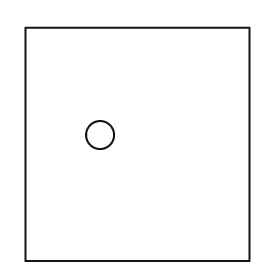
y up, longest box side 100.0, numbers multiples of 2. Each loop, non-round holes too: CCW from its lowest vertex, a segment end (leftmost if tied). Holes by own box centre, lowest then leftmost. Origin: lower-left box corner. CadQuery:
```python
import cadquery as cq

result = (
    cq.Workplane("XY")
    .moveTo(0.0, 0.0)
    .lineTo(96.0, 0.0)
    .lineTo(96.0, 100.0)
    .lineTo(0.0, 100.0)
    .close()
    .moveTo(32.0, 54.0)
    .circle(6.0)
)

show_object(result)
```